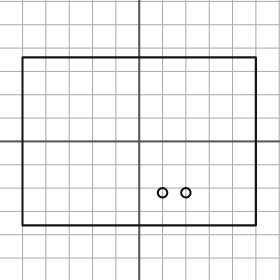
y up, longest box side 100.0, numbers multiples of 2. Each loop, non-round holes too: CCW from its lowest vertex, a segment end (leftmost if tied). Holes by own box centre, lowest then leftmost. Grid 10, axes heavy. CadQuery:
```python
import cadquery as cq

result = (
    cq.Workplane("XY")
    .moveTo(-50.0, -36.0)
    .lineTo(50.0, -36.0)
    .lineTo(50.0, 36.0)
    .lineTo(-50.0, 36.0)
    .close()
    .moveTo(10.0, -22.0)
    .circle(2.0)
    .moveTo(20.0, -22.0)
    .circle(2.0)
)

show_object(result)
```